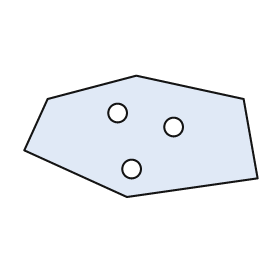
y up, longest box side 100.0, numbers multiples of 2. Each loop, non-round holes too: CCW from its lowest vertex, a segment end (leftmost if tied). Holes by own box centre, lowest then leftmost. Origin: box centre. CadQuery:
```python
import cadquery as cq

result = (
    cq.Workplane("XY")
    .moveTo(-6.0, -26.0)
    .lineTo(50.0, -18.0)
    .lineTo(44.0, 16.0)
    .lineTo(-2.0, 26.0)
    .lineTo(-40.0, 16.0)
    .lineTo(-50.0, -6.0)
    .close()
    .moveTo(-4.0, -14.0)
    .circle(4.0)
    .moveTo(14.0, 4.0)
    .circle(4.0)
    .moveTo(-10.0, 10.0)
    .circle(4.0)
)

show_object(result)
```